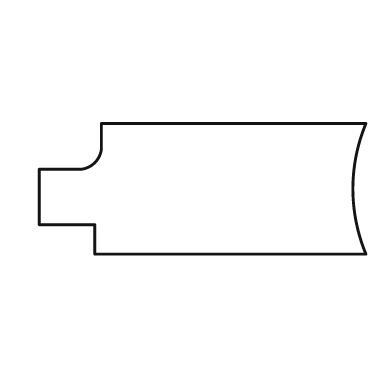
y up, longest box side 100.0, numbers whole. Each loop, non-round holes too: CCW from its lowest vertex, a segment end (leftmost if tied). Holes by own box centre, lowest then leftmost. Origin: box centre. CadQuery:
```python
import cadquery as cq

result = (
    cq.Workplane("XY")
    .moveTo(-33.0, -20.0)
    .lineTo(50.0, -20.0)
    .threePointArc((46.0, 0.0), (50.0, 20.0))
    .lineTo(-31.0, 20.0)
    .lineTo(-31.0, 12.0)
    .threePointArc((-33.0, 8.0), (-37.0, 6.0))
    .lineTo(-50.0, 6.0)
    .lineTo(-50.0, -11.0)
    .lineTo(-33.0, -11.0)
    .close()
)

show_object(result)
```